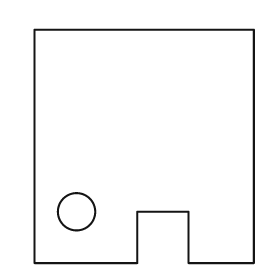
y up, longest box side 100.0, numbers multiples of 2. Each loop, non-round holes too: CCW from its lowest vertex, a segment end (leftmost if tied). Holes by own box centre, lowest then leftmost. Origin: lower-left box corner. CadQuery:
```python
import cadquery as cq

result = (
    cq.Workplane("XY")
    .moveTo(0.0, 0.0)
    .lineTo(44.0, 0.0)
    .lineTo(44.0, 22.0)
    .lineTo(66.0, 22.0)
    .lineTo(66.0, 0.0)
    .lineTo(94.0, 0.0)
    .lineTo(94.0, 100.0)
    .lineTo(0.0, 100.0)
    .close()
    .moveTo(18.0, 22.0)
    .circle(8.0)
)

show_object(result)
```